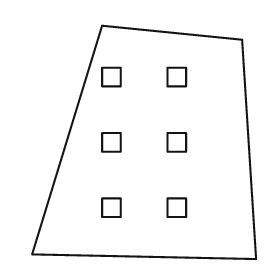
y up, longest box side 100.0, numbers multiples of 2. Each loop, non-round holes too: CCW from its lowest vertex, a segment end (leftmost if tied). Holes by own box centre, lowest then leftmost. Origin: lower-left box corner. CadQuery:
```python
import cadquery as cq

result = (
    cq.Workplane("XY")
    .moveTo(96.0, 0.0)
    .lineTo(90.0, 94.0)
    .lineTo(30.0, 100.0)
    .lineTo(0.0, 2.0)
    .close()
    .moveTo(30.0, 18.0)
    .lineTo(38.0, 18.0)
    .lineTo(38.0, 26.0)
    .lineTo(30.0, 26.0)
    .close()
    .moveTo(58.0, 18.0)
    .lineTo(66.0, 18.0)
    .lineTo(66.0, 26.0)
    .lineTo(58.0, 26.0)
    .close()
    .moveTo(30.0, 46.0)
    .lineTo(38.0, 46.0)
    .lineTo(38.0, 54.0)
    .lineTo(30.0, 54.0)
    .close()
    .moveTo(58.0, 46.0)
    .lineTo(66.0, 46.0)
    .lineTo(66.0, 54.0)
    .lineTo(58.0, 54.0)
    .close()
    .moveTo(30.0, 74.0)
    .lineTo(38.0, 74.0)
    .lineTo(38.0, 82.0)
    .lineTo(30.0, 82.0)
    .close()
    .moveTo(58.0, 74.0)
    .lineTo(66.0, 74.0)
    .lineTo(66.0, 82.0)
    .lineTo(58.0, 82.0)
    .close()
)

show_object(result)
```